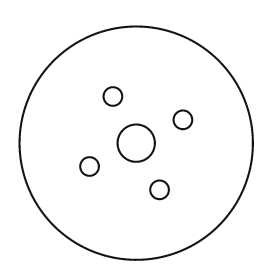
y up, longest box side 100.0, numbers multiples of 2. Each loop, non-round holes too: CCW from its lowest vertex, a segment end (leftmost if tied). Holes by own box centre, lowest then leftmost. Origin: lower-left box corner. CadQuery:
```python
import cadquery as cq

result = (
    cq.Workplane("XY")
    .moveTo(50.0, 50.0)
    .circle(50.0)
    .moveTo(60.0, 30.0)
    .circle(4.0)
    .moveTo(30.0, 40.0)
    .circle(4.0)
    .moveTo(50.0, 50.0)
    .circle(8.0)
    .moveTo(70.0, 60.0)
    .circle(4.0)
    .moveTo(40.0, 70.0)
    .circle(4.0)
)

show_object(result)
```